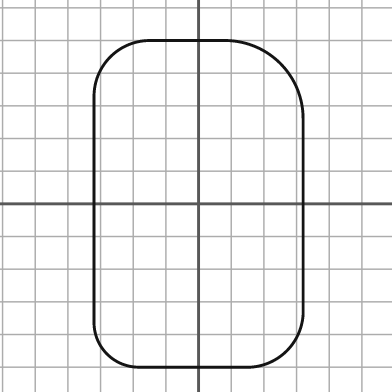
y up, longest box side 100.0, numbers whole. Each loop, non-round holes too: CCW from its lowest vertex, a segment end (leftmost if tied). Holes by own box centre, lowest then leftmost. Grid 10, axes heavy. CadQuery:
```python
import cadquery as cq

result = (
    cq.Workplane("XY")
    .moveTo(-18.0, -50.0)
    .lineTo(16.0, -50.0)
    .threePointArc((27.0, -45.0), (32.0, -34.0))
    .lineTo(32.0, 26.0)
    .threePointArc((25.0, 43.0), (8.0, 50.0))
    .lineTo(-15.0, 50.0)
    .threePointArc((-27.0, 45.0), (-32.0, 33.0))
    .lineTo(-32.0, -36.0)
    .threePointArc((-28.0, -46.0), (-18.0, -50.0))
    .close()
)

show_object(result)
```